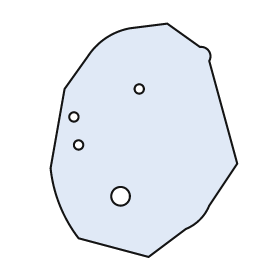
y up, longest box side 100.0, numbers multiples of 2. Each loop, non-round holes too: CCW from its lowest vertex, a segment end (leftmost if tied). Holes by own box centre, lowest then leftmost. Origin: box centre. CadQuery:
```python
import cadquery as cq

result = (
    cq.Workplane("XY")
    .moveTo(2.0, -50.0)
    .lineTo(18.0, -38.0)
    .threePointArc((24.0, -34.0), (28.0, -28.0))
    .lineTo(40.0, -10.0)
    .lineTo(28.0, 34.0)
    .threePointArc((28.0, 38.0), (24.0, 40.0))
    .lineTo(10.0, 50.0)
    .lineTo(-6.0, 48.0)
    .threePointArc((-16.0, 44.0), (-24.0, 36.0))
    .lineTo(-34.0, 22.0)
    .lineTo(-40.0, -12.0)
    .threePointArc((-36.0, -28.0), (-28.0, -42.0))
    .close()
    .moveTo(-10.0, -24.0)
    .circle(4.0)
    .moveTo(-28.0, -2.0)
    .circle(2.0)
    .moveTo(-30.0, 10.0)
    .circle(2.0)
    .moveTo(-2.0, 22.0)
    .circle(2.0)
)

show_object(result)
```